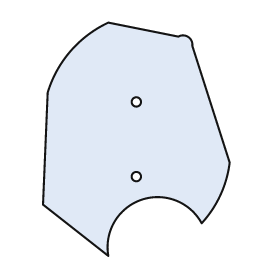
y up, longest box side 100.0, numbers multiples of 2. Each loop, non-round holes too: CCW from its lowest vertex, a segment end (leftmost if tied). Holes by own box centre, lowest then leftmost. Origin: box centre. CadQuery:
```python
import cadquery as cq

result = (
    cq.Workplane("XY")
    .moveTo(-12.0, -50.0)
    .threePointArc((2.0, -26.0), (28.0, -36.0))
    .threePointArc((36.0, -24.0), (40.0, -10.0))
    .lineTo(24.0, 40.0)
    .threePointArc((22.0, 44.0), (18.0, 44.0))
    .lineTo(-12.0, 50.0)
    .threePointArc((-28.0, 38.0), (-38.0, 20.0))
    .lineTo(-40.0, -28.0)
    .close()
    .moveTo(0.0, -16.0)
    .circle(2.0)
    .moveTo(0.0, 16.0)
    .circle(2.0)
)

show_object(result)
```